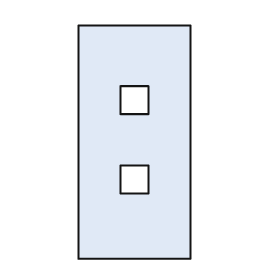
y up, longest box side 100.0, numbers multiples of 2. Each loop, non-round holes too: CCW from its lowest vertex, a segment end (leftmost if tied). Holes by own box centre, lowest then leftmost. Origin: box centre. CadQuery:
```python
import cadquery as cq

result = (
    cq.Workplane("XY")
    .moveTo(-24.0, -50.0)
    .lineTo(24.0, -50.0)
    .lineTo(24.0, 50.0)
    .lineTo(-24.0, 50.0)
    .close()
    .moveTo(-6.0, -22.0)
    .lineTo(6.0, -22.0)
    .lineTo(6.0, -10.0)
    .lineTo(-6.0, -10.0)
    .close()
    .moveTo(-6.0, 12.0)
    .lineTo(6.0, 12.0)
    .lineTo(6.0, 24.0)
    .lineTo(-6.0, 24.0)
    .close()
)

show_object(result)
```